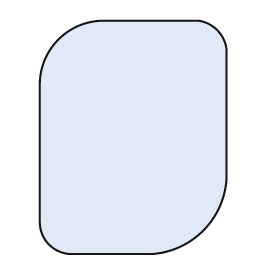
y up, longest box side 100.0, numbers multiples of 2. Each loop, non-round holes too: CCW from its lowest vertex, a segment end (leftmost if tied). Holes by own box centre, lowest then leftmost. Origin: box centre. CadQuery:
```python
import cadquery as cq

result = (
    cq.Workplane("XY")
    .moveTo(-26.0, -50.0)
    .lineTo(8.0, -50.0)
    .threePointArc((30.0, -40.0), (40.0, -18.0))
    .lineTo(40.0, 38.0)
    .threePointArc((36.0, 46.0), (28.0, 50.0))
    .lineTo(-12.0, 50.0)
    .threePointArc((-32.0, 42.0), (-40.0, 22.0))
    .lineTo(-40.0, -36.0)
    .threePointArc((-36.0, -46.0), (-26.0, -50.0))
    .close()
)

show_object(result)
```